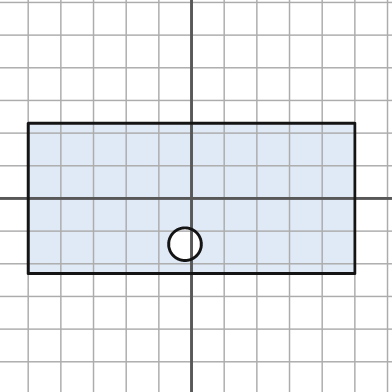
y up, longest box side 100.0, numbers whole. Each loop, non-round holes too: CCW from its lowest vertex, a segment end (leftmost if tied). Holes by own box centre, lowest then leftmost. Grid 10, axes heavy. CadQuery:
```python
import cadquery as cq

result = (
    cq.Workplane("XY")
    .moveTo(-50.0, -23.0)
    .lineTo(50.0, -23.0)
    .lineTo(50.0, 23.0)
    .lineTo(-50.0, 23.0)
    .close()
    .moveTo(-2.0, -14.0)
    .circle(5.0)
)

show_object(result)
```